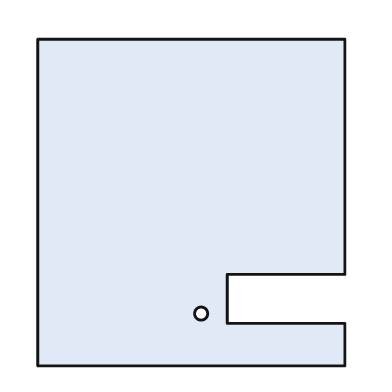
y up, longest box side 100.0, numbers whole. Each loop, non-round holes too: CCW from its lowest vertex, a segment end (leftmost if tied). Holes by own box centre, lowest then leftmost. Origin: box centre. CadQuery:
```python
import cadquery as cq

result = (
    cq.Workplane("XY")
    .moveTo(-47.0, -50.0)
    .lineTo(47.0, -50.0)
    .lineTo(47.0, -37.0)
    .lineTo(11.0, -37.0)
    .lineTo(11.0, -22.0)
    .lineTo(47.0, -22.0)
    .lineTo(47.0, 50.0)
    .lineTo(-47.0, 50.0)
    .close()
    .moveTo(3.0, -34.0)
    .circle(2.0)
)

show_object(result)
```